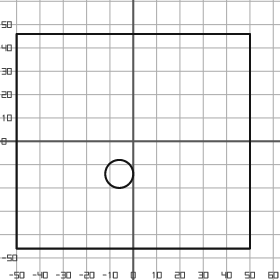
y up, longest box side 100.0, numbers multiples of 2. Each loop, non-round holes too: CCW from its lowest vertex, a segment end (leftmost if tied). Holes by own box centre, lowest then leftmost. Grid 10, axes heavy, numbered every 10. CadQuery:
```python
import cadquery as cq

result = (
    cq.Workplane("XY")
    .moveTo(-50.0, -46.0)
    .lineTo(50.0, -46.0)
    .lineTo(50.0, 46.0)
    .lineTo(-50.0, 46.0)
    .close()
    .moveTo(-6.0, -14.0)
    .circle(6.0)
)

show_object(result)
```